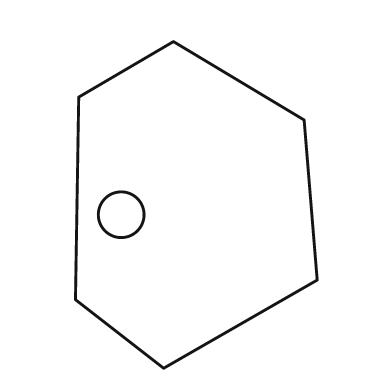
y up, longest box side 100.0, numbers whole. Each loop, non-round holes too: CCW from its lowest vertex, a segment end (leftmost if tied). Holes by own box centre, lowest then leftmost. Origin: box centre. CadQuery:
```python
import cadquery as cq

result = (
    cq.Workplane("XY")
    .moveTo(-10.0, -50.0)
    .lineTo(37.0, -23.0)
    .lineTo(33.0, 26.0)
    .lineTo(-7.0, 50.0)
    .lineTo(-36.0, 33.0)
    .lineTo(-37.0, -29.0)
    .close()
    .moveTo(-23.0, -3.0)
    .circle(7.0)
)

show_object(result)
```